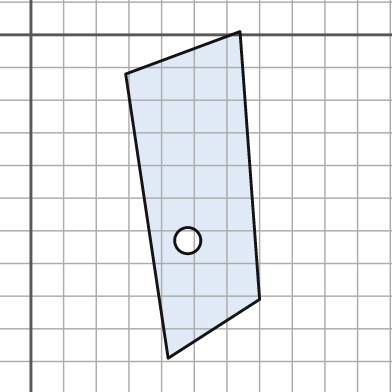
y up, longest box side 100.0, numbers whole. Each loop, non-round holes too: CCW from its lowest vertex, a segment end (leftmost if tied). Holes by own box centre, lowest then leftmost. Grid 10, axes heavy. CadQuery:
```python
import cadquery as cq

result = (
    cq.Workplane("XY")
    .moveTo(42.0, -99.0)
    .lineTo(70.0, -81.0)
    .lineTo(64.0, 1.0)
    .lineTo(29.0, -12.0)
    .close()
    .moveTo(48.0, -63.0)
    .circle(4.0)
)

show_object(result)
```